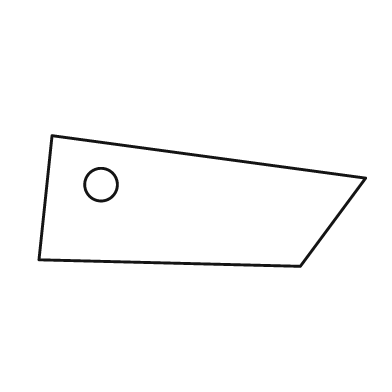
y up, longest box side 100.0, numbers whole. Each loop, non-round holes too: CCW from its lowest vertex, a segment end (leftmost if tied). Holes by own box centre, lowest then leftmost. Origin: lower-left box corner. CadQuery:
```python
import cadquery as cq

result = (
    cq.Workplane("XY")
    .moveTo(80.0, 0.0)
    .lineTo(100.0, 27.0)
    .lineTo(4.0, 40.0)
    .lineTo(0.0, 2.0)
    .close()
    .moveTo(19.0, 25.0)
    .circle(5.0)
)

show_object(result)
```